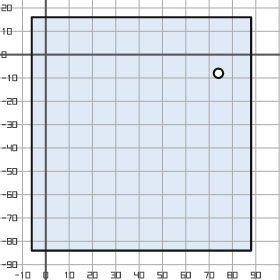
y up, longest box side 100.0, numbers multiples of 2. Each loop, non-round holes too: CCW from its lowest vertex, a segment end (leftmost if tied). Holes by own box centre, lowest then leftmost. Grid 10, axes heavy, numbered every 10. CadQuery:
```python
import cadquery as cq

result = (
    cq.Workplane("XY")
    .moveTo(-6.0, -84.0)
    .lineTo(88.0, -84.0)
    .lineTo(88.0, 16.0)
    .lineTo(-6.0, 16.0)
    .close()
    .moveTo(74.0, -8.0)
    .circle(2.0)
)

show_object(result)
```